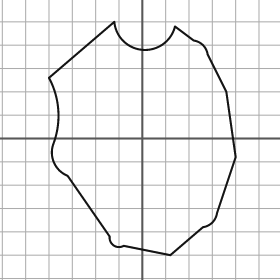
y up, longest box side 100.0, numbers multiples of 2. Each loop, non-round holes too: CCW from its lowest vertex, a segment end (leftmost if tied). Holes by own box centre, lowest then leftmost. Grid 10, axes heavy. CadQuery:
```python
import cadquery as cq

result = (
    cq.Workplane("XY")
    .moveTo(12.0, -50.0)
    .lineTo(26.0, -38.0)
    .threePointArc((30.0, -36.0), (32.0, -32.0))
    .lineTo(40.0, -8.0)
    .lineTo(36.0, 20.0)
    .lineTo(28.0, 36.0)
    .threePointArc((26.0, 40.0), (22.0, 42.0))
    .lineTo(14.0, 48.0)
    .threePointArc((0.0, 38.0), (-12.0, 50.0))
    .lineTo(-40.0, 26.0)
    .threePointArc((-36.0, 12.0), (-38.0, -2.0))
    .threePointArc((-38.0, -10.0), (-32.0, -16.0))
    .lineTo(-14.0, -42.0)
    .threePointArc((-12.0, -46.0), (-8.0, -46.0))
    .close()
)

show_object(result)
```